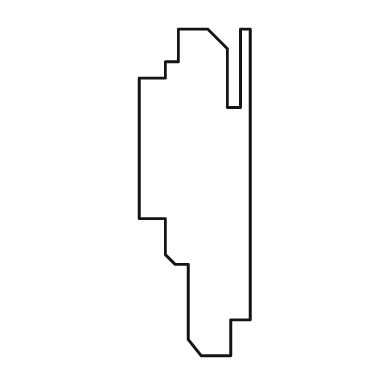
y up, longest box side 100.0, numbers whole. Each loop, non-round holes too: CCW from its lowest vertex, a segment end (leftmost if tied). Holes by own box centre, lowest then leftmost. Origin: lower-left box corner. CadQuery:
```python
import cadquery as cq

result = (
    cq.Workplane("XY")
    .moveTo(19.0, 0.0)
    .lineTo(28.0, 0.0)
    .lineTo(28.0, 11.0)
    .lineTo(34.0, 11.0)
    .lineTo(34.0, 100.0)
    .lineTo(31.0, 100.0)
    .lineTo(31.0, 76.0)
    .lineTo(27.0, 76.0)
    .lineTo(27.0, 94.0)
    .lineTo(21.0, 100.0)
    .lineTo(12.0, 100.0)
    .lineTo(12.0, 90.0)
    .lineTo(8.0, 90.0)
    .lineTo(8.0, 85.0)
    .lineTo(0.0, 85.0)
    .lineTo(0.0, 42.0)
    .lineTo(8.0, 42.0)
    .lineTo(8.0, 31.0)
    .lineTo(11.0, 28.0)
    .lineTo(15.0, 28.0)
    .lineTo(15.0, 5.0)
    .close()
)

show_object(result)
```